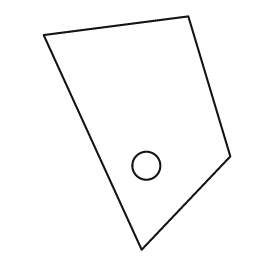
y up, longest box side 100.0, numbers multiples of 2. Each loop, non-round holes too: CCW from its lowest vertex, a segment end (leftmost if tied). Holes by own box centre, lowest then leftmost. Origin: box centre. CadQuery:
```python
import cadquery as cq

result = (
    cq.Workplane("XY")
    .moveTo(2.0, -50.0)
    .lineTo(40.0, -10.0)
    .lineTo(22.0, 50.0)
    .lineTo(-40.0, 42.0)
    .close()
    .moveTo(4.0, -14.0)
    .circle(6.0)
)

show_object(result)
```